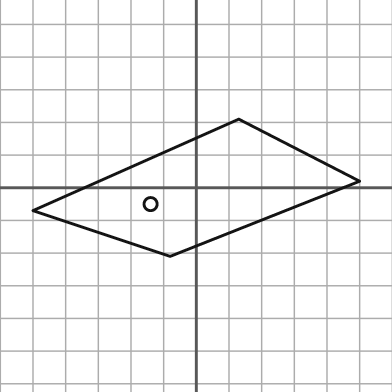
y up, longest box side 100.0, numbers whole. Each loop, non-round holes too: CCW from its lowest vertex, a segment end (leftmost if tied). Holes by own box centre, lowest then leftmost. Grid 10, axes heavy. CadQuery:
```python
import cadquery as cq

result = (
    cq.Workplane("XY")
    .moveTo(-8.0, -21.0)
    .lineTo(50.0, 2.0)
    .lineTo(13.0, 21.0)
    .lineTo(-50.0, -7.0)
    .close()
    .moveTo(-14.0, -5.0)
    .circle(2.0)
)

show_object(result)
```